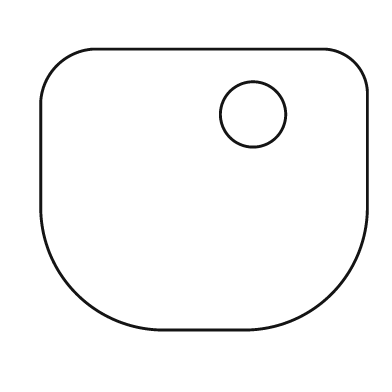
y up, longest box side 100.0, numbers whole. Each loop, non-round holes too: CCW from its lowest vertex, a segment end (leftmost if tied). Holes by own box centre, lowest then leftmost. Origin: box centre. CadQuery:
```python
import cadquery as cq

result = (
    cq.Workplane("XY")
    .moveTo(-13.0, -43.0)
    .lineTo(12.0, -43.0)
    .threePointArc((39.0, -32.0), (50.0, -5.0))
    .lineTo(50.0, 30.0)
    .threePointArc((46.0, 39.0), (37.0, 43.0))
    .lineTo(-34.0, 43.0)
    .threePointArc((-45.0, 38.0), (-50.0, 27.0))
    .lineTo(-50.0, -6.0)
    .threePointArc((-39.0, -32.0), (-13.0, -43.0))
    .close()
    .moveTo(15.0, 23.0)
    .circle(10.0)
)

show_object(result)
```